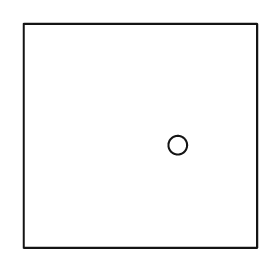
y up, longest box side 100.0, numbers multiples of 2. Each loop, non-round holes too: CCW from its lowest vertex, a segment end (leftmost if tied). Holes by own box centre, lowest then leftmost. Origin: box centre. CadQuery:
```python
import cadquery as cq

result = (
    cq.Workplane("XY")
    .moveTo(-50.0, -48.0)
    .lineTo(50.0, -48.0)
    .lineTo(50.0, 48.0)
    .lineTo(-50.0, 48.0)
    .close()
    .moveTo(16.0, -4.0)
    .circle(4.0)
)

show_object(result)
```